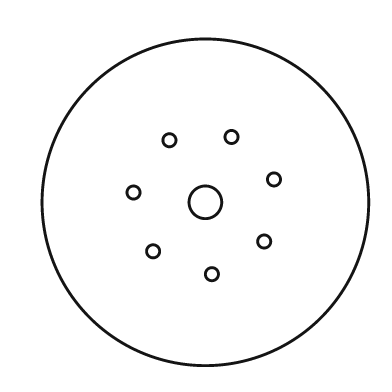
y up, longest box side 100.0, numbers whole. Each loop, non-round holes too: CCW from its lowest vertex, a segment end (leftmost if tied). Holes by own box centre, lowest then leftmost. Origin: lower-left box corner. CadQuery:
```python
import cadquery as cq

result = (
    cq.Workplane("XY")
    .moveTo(50.0, 50.0)
    .circle(50.0)
    .moveTo(52.0, 28.0)
    .circle(2.0)
    .moveTo(34.0, 35.0)
    .circle(2.0)
    .moveTo(68.0, 38.0)
    .circle(2.0)
    .moveTo(50.0, 50.0)
    .circle(5.0)
    .moveTo(28.0, 53.0)
    .circle(2.0)
    .moveTo(71.0, 57.0)
    .circle(2.0)
    .moveTo(39.0, 69.0)
    .circle(2.0)
    .moveTo(58.0, 70.0)
    .circle(2.0)
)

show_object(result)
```